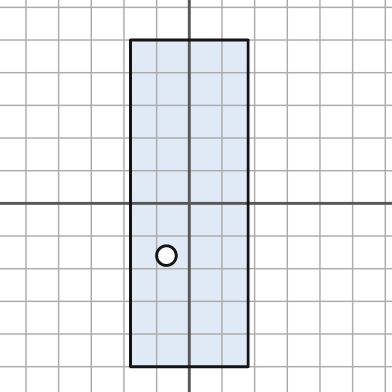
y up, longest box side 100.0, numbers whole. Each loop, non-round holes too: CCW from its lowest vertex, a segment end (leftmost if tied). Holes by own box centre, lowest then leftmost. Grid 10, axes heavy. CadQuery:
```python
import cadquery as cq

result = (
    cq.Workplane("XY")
    .moveTo(-18.0, -50.0)
    .lineTo(18.0, -50.0)
    .lineTo(18.0, 50.0)
    .lineTo(-18.0, 50.0)
    .close()
    .moveTo(-7.0, -16.0)
    .circle(3.0)
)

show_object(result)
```